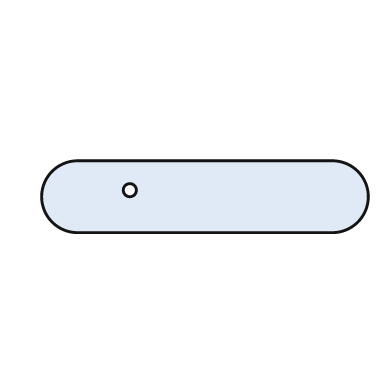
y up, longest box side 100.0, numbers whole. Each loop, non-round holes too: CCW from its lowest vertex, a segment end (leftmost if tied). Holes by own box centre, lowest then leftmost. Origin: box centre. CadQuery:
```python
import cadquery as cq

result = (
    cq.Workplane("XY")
    .moveTo(-39.0, -11.0)
    .lineTo(39.0, -11.0)
    .threePointArc((50.0, 0.0), (39.0, 11.0))
    .lineTo(-39.0, 11.0)
    .threePointArc((-50.0, 0.0), (-39.0, -11.0))
    .close()
    .moveTo(-23.0, 2.0)
    .circle(2.0)
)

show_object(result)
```